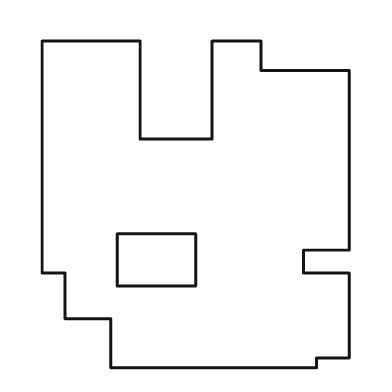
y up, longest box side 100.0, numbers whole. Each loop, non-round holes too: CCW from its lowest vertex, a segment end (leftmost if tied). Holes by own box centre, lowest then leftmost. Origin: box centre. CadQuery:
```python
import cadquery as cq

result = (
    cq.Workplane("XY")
    .moveTo(-26.0, -50.0)
    .lineTo(37.0, -50.0)
    .lineTo(37.0, -47.0)
    .lineTo(47.0, -47.0)
    .lineTo(47.0, -21.0)
    .lineTo(33.0, -21.0)
    .lineTo(33.0, -14.0)
    .lineTo(47.0, -14.0)
    .lineTo(47.0, 41.0)
    .lineTo(20.0, 41.0)
    .lineTo(20.0, 50.0)
    .lineTo(5.0, 50.0)
    .lineTo(5.0, 20.0)
    .lineTo(-17.0, 20.0)
    .lineTo(-17.0, 50.0)
    .lineTo(-47.0, 50.0)
    .lineTo(-47.0, -21.0)
    .lineTo(-40.0, -21.0)
    .lineTo(-40.0, -35.0)
    .lineTo(-26.0, -35.0)
    .close()
    .moveTo(-24.0, -25.0)
    .lineTo(0.0, -25.0)
    .lineTo(0.0, -9.0)
    .lineTo(-24.0, -9.0)
    .close()
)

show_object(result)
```